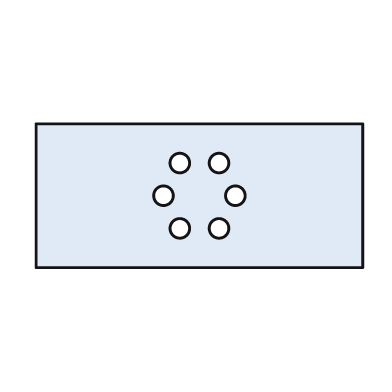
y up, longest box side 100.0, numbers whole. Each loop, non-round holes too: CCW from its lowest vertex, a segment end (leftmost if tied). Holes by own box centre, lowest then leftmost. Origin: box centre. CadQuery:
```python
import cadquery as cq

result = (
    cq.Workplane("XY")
    .moveTo(-50.0, -22.0)
    .lineTo(50.0, -22.0)
    .lineTo(50.0, 22.0)
    .lineTo(-50.0, 22.0)
    .close()
    .moveTo(-6.0, -10.0)
    .circle(3.0)
    .moveTo(6.0, -10.0)
    .circle(3.0)
    .moveTo(-11.0, 0.0)
    .circle(3.0)
    .moveTo(11.0, 0.0)
    .circle(3.0)
    .moveTo(-6.0, 10.0)
    .circle(3.0)
    .moveTo(6.0, 10.0)
    .circle(3.0)
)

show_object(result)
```